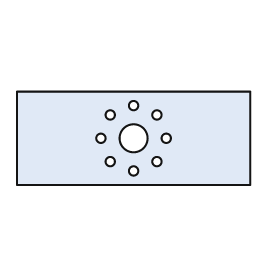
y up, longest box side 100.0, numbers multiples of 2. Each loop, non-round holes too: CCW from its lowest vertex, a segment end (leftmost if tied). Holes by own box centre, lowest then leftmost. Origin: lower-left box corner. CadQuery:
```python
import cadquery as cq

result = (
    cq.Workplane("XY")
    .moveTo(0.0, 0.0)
    .lineTo(100.0, 0.0)
    .lineTo(100.0, 40.0)
    .lineTo(0.0, 40.0)
    .close()
    .moveTo(50.0, 6.0)
    .circle(2.0)
    .moveTo(40.0, 10.0)
    .circle(2.0)
    .moveTo(60.0, 10.0)
    .circle(2.0)
    .moveTo(36.0, 20.0)
    .circle(2.0)
    .moveTo(50.0, 20.0)
    .circle(6.0)
    .moveTo(64.0, 20.0)
    .circle(2.0)
    .moveTo(40.0, 30.0)
    .circle(2.0)
    .moveTo(60.0, 30.0)
    .circle(2.0)
    .moveTo(50.0, 34.0)
    .circle(2.0)
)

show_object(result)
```